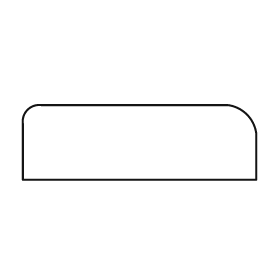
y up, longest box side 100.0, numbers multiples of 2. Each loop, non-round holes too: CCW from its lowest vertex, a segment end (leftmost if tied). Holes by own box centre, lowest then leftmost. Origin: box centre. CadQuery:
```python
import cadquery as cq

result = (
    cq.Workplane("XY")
    .moveTo(-50.0, -16.0)
    .lineTo(50.0, -16.0)
    .lineTo(50.0, 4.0)
    .threePointArc((46.0, 12.0), (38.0, 16.0))
    .lineTo(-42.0, 16.0)
    .threePointArc((-48.0, 14.0), (-50.0, 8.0))
    .close()
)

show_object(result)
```